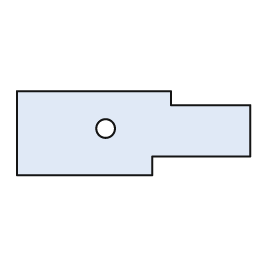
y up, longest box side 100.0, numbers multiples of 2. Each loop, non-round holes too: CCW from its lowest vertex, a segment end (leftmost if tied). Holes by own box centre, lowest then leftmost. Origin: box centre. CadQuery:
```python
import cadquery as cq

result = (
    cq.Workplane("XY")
    .moveTo(-50.0, -18.0)
    .lineTo(8.0, -18.0)
    .lineTo(8.0, -10.0)
    .lineTo(50.0, -10.0)
    .lineTo(50.0, 12.0)
    .lineTo(16.0, 12.0)
    .lineTo(16.0, 18.0)
    .lineTo(-50.0, 18.0)
    .close()
    .moveTo(-12.0, 2.0)
    .circle(4.0)
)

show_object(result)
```